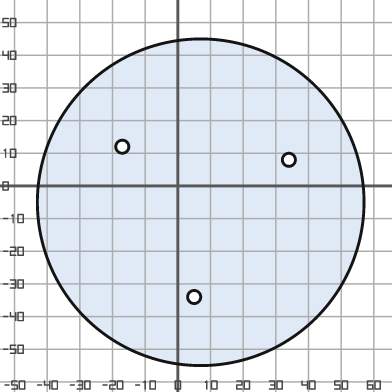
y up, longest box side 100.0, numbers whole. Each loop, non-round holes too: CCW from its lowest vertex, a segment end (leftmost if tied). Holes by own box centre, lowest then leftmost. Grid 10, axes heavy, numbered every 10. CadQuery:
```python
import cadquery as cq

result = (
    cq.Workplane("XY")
    .moveTo(7.0, -5.0)
    .circle(50.0)
    .moveTo(5.0, -34.0)
    .circle(2.0)
    .moveTo(34.0, 8.0)
    .circle(2.0)
    .moveTo(-17.0, 12.0)
    .circle(2.0)
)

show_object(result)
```